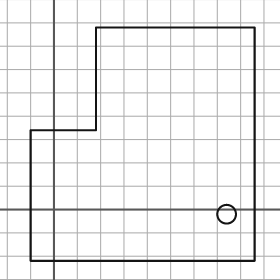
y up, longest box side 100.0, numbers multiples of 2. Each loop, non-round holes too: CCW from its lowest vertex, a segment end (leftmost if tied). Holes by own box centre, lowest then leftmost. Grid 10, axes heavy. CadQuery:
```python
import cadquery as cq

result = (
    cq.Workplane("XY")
    .moveTo(-10.0, -22.0)
    .lineTo(86.0, -22.0)
    .lineTo(86.0, 78.0)
    .lineTo(18.0, 78.0)
    .lineTo(18.0, 34.0)
    .lineTo(-10.0, 34.0)
    .close()
    .moveTo(74.0, -2.0)
    .circle(4.0)
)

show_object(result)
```